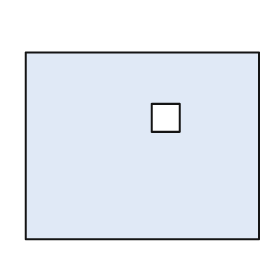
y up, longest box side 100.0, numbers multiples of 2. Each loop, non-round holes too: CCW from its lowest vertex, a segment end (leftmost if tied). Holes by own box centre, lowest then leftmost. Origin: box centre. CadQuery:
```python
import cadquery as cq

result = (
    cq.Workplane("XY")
    .moveTo(-50.0, -40.0)
    .lineTo(50.0, -40.0)
    .lineTo(50.0, 40.0)
    .lineTo(-50.0, 40.0)
    .close()
    .moveTo(4.0, 6.0)
    .lineTo(16.0, 6.0)
    .lineTo(16.0, 18.0)
    .lineTo(4.0, 18.0)
    .close()
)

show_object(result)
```